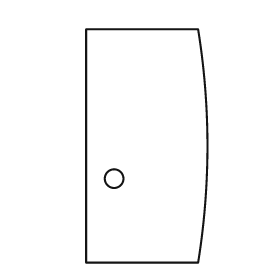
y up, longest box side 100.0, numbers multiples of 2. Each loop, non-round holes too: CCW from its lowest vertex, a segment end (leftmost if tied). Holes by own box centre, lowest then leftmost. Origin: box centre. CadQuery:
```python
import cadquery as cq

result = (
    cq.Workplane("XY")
    .moveTo(-26.0, -50.0)
    .lineTo(22.0, -50.0)
    .threePointArc((26.0, 0.0), (22.0, 50.0))
    .lineTo(-26.0, 50.0)
    .close()
    .moveTo(-14.0, -14.0)
    .circle(4.0)
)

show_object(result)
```